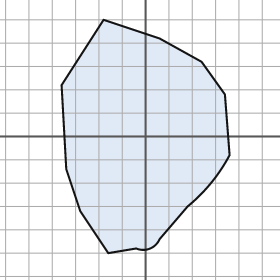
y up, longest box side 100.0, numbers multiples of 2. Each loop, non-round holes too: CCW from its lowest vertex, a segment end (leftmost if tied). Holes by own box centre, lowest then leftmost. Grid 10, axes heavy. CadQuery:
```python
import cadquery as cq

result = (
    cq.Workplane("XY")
    .moveTo(-16.0, -50.0)
    .lineTo(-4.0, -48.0)
    .threePointArc((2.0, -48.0), (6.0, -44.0))
    .lineTo(18.0, -30.0)
    .threePointArc((28.0, -20.0), (36.0, -8.0))
    .lineTo(34.0, 18.0)
    .lineTo(24.0, 32.0)
    .lineTo(6.0, 42.0)
    .lineTo(-18.0, 50.0)
    .lineTo(-36.0, 22.0)
    .lineTo(-34.0, -14.0)
    .lineTo(-28.0, -32.0)
    .close()
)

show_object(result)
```